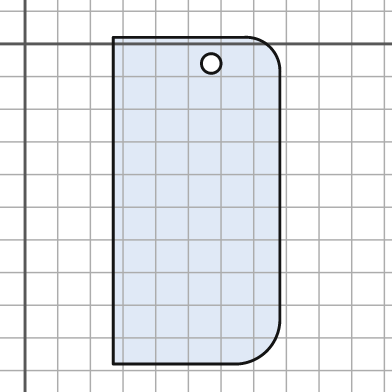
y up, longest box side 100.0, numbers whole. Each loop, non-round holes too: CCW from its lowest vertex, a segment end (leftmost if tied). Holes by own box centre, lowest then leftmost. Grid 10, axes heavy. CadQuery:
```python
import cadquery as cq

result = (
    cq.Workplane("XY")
    .moveTo(27.0, -98.0)
    .lineTo(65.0, -98.0)
    .threePointArc((74.0, -94.0), (78.0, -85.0))
    .lineTo(78.0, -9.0)
    .threePointArc((75.0, -1.0), (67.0, 2.0))
    .lineTo(27.0, 2.0)
    .close()
    .moveTo(57.0, -6.0)
    .circle(3.0)
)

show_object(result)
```